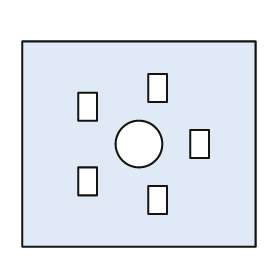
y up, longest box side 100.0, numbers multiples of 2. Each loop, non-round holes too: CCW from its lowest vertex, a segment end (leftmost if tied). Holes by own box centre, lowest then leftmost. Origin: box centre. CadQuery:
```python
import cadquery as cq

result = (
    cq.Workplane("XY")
    .moveTo(-50.0, -44.0)
    .lineTo(50.0, -44.0)
    .lineTo(50.0, 44.0)
    .lineTo(-50.0, 44.0)
    .close()
    .moveTo(4.0, -30.0)
    .lineTo(12.0, -30.0)
    .lineTo(12.0, -18.0)
    .lineTo(4.0, -18.0)
    .close()
    .moveTo(-26.0, -22.0)
    .lineTo(-18.0, -22.0)
    .lineTo(-18.0, -10.0)
    .lineTo(-26.0, -10.0)
    .close()
    .moveTo(0.0, 0.0)
    .circle(10.0)
    .moveTo(22.0, -6.0)
    .lineTo(30.0, -6.0)
    .lineTo(30.0, 6.0)
    .lineTo(22.0, 6.0)
    .close()
    .moveTo(-26.0, 10.0)
    .lineTo(-18.0, 10.0)
    .lineTo(-18.0, 22.0)
    .lineTo(-26.0, 22.0)
    .close()
    .moveTo(4.0, 18.0)
    .lineTo(12.0, 18.0)
    .lineTo(12.0, 30.0)
    .lineTo(4.0, 30.0)
    .close()
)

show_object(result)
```